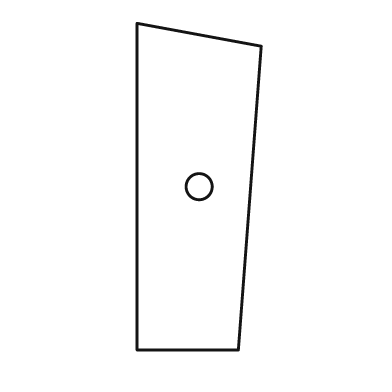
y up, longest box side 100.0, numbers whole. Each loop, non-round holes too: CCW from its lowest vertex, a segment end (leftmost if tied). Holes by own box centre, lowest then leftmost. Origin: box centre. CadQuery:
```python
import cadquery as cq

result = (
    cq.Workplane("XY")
    .moveTo(-19.0, -50.0)
    .lineTo(12.0, -50.0)
    .lineTo(19.0, 43.0)
    .lineTo(-19.0, 50.0)
    .close()
    .moveTo(0.0, 0.0)
    .circle(4.0)
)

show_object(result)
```